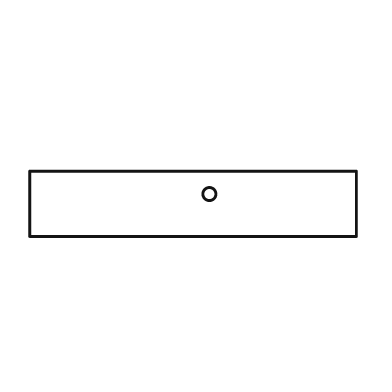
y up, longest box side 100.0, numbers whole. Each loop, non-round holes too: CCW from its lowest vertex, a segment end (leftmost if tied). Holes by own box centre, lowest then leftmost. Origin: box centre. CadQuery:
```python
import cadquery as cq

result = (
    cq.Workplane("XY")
    .moveTo(-50.0, -10.0)
    .lineTo(50.0, -10.0)
    .lineTo(50.0, 10.0)
    .lineTo(-50.0, 10.0)
    .close()
    .moveTo(5.0, 3.0)
    .circle(2.0)
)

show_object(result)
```